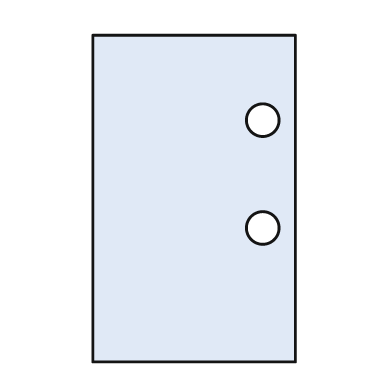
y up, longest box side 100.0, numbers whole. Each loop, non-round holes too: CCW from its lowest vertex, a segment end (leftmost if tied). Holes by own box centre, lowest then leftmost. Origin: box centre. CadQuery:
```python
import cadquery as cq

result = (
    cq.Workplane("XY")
    .moveTo(-31.0, -50.0)
    .lineTo(31.0, -50.0)
    .lineTo(31.0, 50.0)
    .lineTo(-31.0, 50.0)
    .close()
    .moveTo(21.0, -9.0)
    .circle(5.0)
    .moveTo(21.0, 24.0)
    .circle(5.0)
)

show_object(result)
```